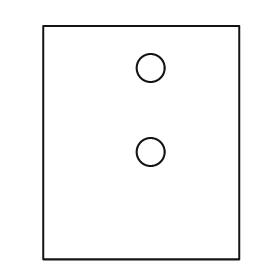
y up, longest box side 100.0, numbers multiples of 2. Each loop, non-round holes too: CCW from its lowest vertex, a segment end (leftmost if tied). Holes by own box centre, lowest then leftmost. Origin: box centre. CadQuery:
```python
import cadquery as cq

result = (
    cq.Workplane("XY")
    .moveTo(-42.0, -50.0)
    .lineTo(42.0, -50.0)
    .lineTo(42.0, 50.0)
    .lineTo(-42.0, 50.0)
    .close()
    .moveTo(4.0, -4.0)
    .circle(6.0)
    .moveTo(4.0, 32.0)
    .circle(6.0)
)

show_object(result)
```